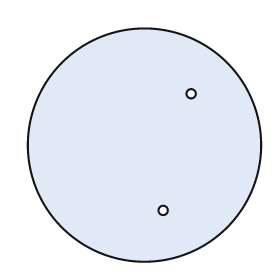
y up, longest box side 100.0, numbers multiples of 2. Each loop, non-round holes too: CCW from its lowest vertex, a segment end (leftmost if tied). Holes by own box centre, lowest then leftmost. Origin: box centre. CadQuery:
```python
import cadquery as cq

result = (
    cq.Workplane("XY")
    .moveTo(0.0, 0.0)
    .circle(50.0)
    .moveTo(8.0, -28.0)
    .circle(2.0)
    .moveTo(20.0, 22.0)
    .circle(2.0)
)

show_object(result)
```